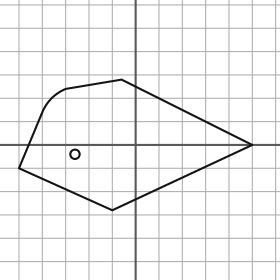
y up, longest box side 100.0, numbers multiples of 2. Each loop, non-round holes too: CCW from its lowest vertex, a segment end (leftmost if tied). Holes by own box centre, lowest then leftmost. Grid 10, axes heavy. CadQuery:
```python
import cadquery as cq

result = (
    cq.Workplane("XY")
    .moveTo(-10.0, -28.0)
    .lineTo(50.0, 0.0)
    .lineTo(-6.0, 28.0)
    .lineTo(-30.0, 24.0)
    .threePointArc((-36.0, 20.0), (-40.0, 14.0))
    .lineTo(-50.0, -10.0)
    .close()
    .moveTo(-26.0, -4.0)
    .circle(2.0)
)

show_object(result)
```